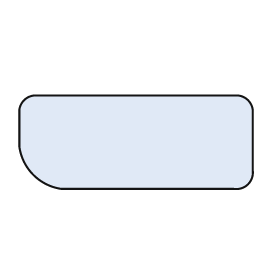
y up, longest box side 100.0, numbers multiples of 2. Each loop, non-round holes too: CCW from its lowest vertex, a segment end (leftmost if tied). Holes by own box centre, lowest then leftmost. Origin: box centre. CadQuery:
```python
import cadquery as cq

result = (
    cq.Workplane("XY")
    .moveTo(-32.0, -20.0)
    .lineTo(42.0, -20.0)
    .threePointArc((48.0, -18.0), (50.0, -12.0))
    .lineTo(50.0, 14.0)
    .threePointArc((48.0, 18.0), (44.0, 20.0))
    .lineTo(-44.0, 20.0)
    .threePointArc((-48.0, 18.0), (-50.0, 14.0))
    .lineTo(-50.0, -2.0)
    .threePointArc((-44.0, -14.0), (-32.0, -20.0))
    .close()
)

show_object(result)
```